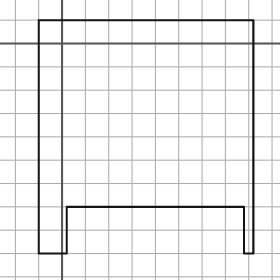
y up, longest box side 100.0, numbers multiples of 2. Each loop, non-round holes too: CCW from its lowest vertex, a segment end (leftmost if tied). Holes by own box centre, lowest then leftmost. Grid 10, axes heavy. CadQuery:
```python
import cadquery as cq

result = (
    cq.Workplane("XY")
    .moveTo(-10.0, -90.0)
    .lineTo(2.0, -90.0)
    .lineTo(2.0, -70.0)
    .lineTo(78.0, -70.0)
    .lineTo(78.0, -90.0)
    .lineTo(82.0, -90.0)
    .lineTo(82.0, 10.0)
    .lineTo(-10.0, 10.0)
    .close()
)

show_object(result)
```